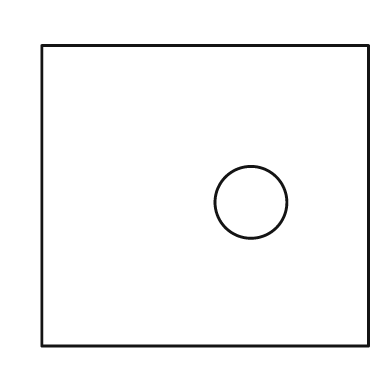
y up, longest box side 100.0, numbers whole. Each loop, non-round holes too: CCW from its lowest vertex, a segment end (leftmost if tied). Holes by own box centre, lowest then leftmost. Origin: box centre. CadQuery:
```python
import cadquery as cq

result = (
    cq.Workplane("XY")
    .moveTo(-50.0, -46.0)
    .lineTo(50.0, -46.0)
    .lineTo(50.0, 46.0)
    .lineTo(-50.0, 46.0)
    .close()
    .moveTo(14.0, -2.0)
    .circle(11.0)
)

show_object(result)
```